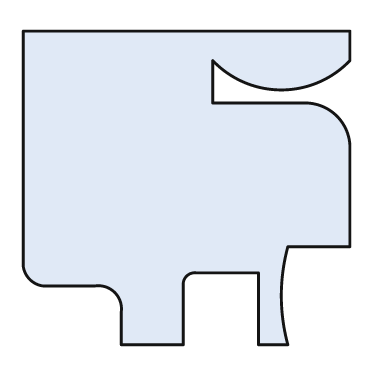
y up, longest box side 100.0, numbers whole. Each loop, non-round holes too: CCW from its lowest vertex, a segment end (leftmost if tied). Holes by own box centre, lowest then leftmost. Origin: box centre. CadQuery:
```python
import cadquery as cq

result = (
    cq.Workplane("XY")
    .moveTo(-20.0, -48.0)
    .lineTo(-1.0, -48.0)
    .lineTo(-1.0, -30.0)
    .threePointArc((0.0, -27.0), (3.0, -26.0))
    .lineTo(22.0, -26.0)
    .lineTo(22.0, -48.0)
    .lineTo(31.0, -48.0)
    .threePointArc((29.0, -33.0), (31.0, -18.0))
    .lineTo(50.0, -18.0)
    .lineTo(50.0, 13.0)
    .threePointArc((46.0, 22.0), (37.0, 26.0))
    .lineTo(8.0, 26.0)
    .lineTo(8.0, 39.0)
    .threePointArc((29.0, 30.0), (50.0, 39.0))
    .lineTo(50.0, 48.0)
    .lineTo(-50.0, 48.0)
    .lineTo(-50.0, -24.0)
    .threePointArc((-48.0, -28.0), (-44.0, -30.0))
    .lineTo(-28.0, -30.0)
    .threePointArc((-22.0, -32.0), (-20.0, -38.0))
    .close()
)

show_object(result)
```